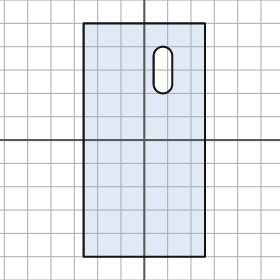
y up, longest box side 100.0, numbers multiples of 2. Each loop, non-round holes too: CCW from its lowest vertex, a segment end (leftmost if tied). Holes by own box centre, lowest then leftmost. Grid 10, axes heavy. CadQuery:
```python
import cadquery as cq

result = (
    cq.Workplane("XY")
    .moveTo(-26.0, -50.0)
    .lineTo(26.0, -50.0)
    .lineTo(26.0, 50.0)
    .lineTo(-26.0, 50.0)
    .close()
    .moveTo(4.0, 24.0)
    .threePointArc((8.0, 20.0), (12.0, 24.0))
    .lineTo(12.0, 36.0)
    .threePointArc((8.0, 40.0), (4.0, 36.0))
    .close()
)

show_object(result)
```